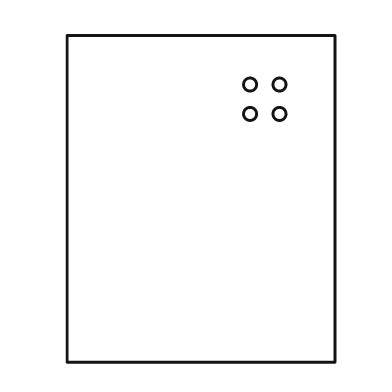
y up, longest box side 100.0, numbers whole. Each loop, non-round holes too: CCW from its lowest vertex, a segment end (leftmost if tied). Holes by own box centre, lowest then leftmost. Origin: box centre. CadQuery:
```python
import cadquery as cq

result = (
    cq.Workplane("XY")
    .moveTo(-41.0, -50.0)
    .lineTo(41.0, -50.0)
    .lineTo(41.0, 50.0)
    .lineTo(-41.0, 50.0)
    .close()
    .moveTo(15.0, 26.0)
    .circle(2.0)
    .moveTo(24.0, 26.0)
    .circle(2.0)
    .moveTo(15.0, 35.0)
    .circle(2.0)
    .moveTo(24.0, 35.0)
    .circle(2.0)
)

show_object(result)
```